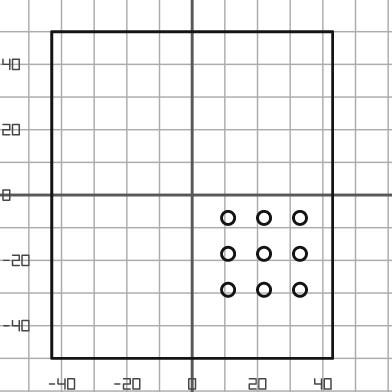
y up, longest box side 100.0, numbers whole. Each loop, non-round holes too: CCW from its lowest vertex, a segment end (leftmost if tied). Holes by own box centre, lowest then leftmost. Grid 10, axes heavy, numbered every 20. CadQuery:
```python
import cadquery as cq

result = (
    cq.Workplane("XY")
    .moveTo(-43.0, -50.0)
    .lineTo(43.0, -50.0)
    .lineTo(43.0, 50.0)
    .lineTo(-43.0, 50.0)
    .close()
    .moveTo(11.0, -29.0)
    .circle(2.0)
    .moveTo(22.0, -29.0)
    .circle(2.0)
    .moveTo(33.0, -29.0)
    .circle(2.0)
    .moveTo(11.0, -18.0)
    .circle(2.0)
    .moveTo(22.0, -18.0)
    .circle(2.0)
    .moveTo(33.0, -18.0)
    .circle(2.0)
    .moveTo(11.0, -7.0)
    .circle(2.0)
    .moveTo(22.0, -7.0)
    .circle(2.0)
    .moveTo(33.0, -7.0)
    .circle(2.0)
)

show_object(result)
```